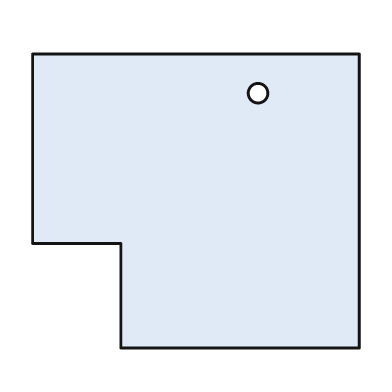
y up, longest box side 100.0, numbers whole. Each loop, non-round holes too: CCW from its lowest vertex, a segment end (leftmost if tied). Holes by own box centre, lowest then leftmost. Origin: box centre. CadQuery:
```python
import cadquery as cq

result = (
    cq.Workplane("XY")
    .moveTo(-23.0, -45.0)
    .lineTo(50.0, -45.0)
    .lineTo(50.0, 45.0)
    .lineTo(-50.0, 45.0)
    .lineTo(-50.0, -13.0)
    .lineTo(-23.0, -13.0)
    .close()
    .moveTo(19.0, 33.0)
    .circle(3.0)
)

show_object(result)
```